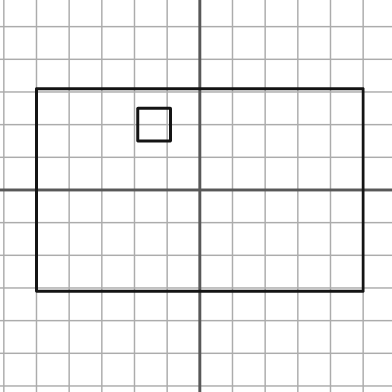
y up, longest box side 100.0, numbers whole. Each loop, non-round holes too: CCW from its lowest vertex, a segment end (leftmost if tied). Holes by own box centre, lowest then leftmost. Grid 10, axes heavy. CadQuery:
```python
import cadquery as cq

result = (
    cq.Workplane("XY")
    .moveTo(-50.0, -31.0)
    .lineTo(50.0, -31.0)
    .lineTo(50.0, 31.0)
    .lineTo(-50.0, 31.0)
    .close()
    .moveTo(-19.0, 15.0)
    .lineTo(-9.0, 15.0)
    .lineTo(-9.0, 25.0)
    .lineTo(-19.0, 25.0)
    .close()
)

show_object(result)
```